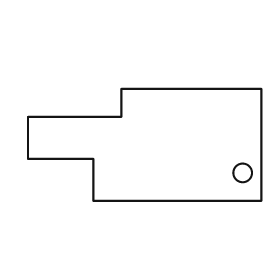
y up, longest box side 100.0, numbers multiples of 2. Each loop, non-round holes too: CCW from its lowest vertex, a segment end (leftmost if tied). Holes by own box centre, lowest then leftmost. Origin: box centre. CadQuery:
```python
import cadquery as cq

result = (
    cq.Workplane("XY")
    .moveTo(-22.0, -24.0)
    .lineTo(50.0, -24.0)
    .lineTo(50.0, 24.0)
    .lineTo(-10.0, 24.0)
    .lineTo(-10.0, 12.0)
    .lineTo(-50.0, 12.0)
    .lineTo(-50.0, -6.0)
    .lineTo(-22.0, -6.0)
    .close()
    .moveTo(42.0, -12.0)
    .circle(4.0)
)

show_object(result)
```